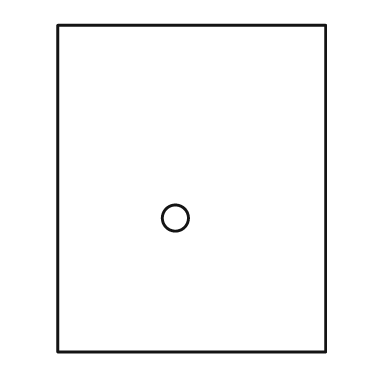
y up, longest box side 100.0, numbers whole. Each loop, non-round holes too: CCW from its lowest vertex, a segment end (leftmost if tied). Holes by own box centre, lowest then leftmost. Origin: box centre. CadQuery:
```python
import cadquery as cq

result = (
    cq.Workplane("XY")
    .moveTo(-41.0, -50.0)
    .lineTo(41.0, -50.0)
    .lineTo(41.0, 50.0)
    .lineTo(-41.0, 50.0)
    .close()
    .moveTo(-5.0, -9.0)
    .circle(4.0)
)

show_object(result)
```